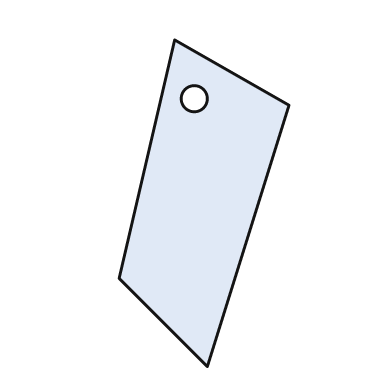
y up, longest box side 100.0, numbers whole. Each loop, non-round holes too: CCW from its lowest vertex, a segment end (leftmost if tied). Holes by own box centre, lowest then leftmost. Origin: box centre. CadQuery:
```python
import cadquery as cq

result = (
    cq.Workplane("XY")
    .moveTo(1.0, -50.0)
    .lineTo(26.0, 30.0)
    .lineTo(-9.0, 50.0)
    .lineTo(-26.0, -23.0)
    .close()
    .moveTo(-3.0, 32.0)
    .circle(4.0)
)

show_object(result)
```